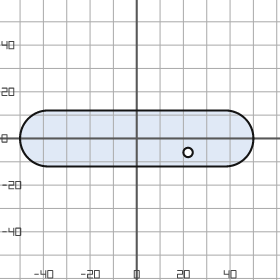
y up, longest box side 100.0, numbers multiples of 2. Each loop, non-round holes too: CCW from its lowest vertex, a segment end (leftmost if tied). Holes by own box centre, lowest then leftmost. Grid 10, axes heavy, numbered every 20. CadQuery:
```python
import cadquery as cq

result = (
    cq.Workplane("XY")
    .moveTo(-38.0, -12.0)
    .lineTo(38.0, -12.0)
    .threePointArc((50.0, 0.0), (38.0, 12.0))
    .lineTo(-38.0, 12.0)
    .threePointArc((-50.0, 0.0), (-38.0, -12.0))
    .close()
    .moveTo(22.0, -6.0)
    .circle(2.0)
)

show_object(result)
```